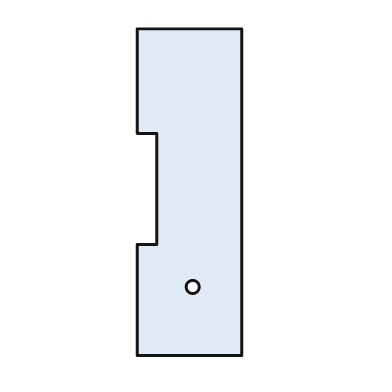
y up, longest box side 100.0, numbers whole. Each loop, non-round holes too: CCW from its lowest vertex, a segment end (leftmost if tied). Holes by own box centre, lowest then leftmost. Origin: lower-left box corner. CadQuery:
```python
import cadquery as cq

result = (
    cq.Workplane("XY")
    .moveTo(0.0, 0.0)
    .lineTo(32.0, 0.0)
    .lineTo(32.0, 100.0)
    .lineTo(0.0, 100.0)
    .lineTo(0.0, 68.0)
    .lineTo(6.0, 68.0)
    .lineTo(6.0, 34.0)
    .lineTo(0.0, 34.0)
    .close()
    .moveTo(17.0, 21.0)
    .circle(2.0)
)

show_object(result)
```